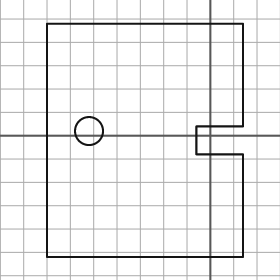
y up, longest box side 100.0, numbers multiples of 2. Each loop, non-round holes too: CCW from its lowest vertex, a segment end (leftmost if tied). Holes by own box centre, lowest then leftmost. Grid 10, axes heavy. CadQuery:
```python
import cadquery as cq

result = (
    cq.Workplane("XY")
    .moveTo(-70.0, -52.0)
    .lineTo(14.0, -52.0)
    .lineTo(14.0, -8.0)
    .lineTo(-6.0, -8.0)
    .lineTo(-6.0, 4.0)
    .lineTo(14.0, 4.0)
    .lineTo(14.0, 48.0)
    .lineTo(-70.0, 48.0)
    .close()
    .moveTo(-52.0, 2.0)
    .circle(6.0)
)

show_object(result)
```